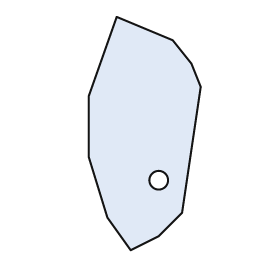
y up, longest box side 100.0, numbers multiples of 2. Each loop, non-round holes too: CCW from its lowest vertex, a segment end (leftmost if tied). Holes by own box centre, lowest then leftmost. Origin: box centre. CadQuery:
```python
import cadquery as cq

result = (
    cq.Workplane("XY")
    .moveTo(-6.0, -50.0)
    .lineTo(6.0, -44.0)
    .lineTo(16.0, -34.0)
    .lineTo(24.0, 20.0)
    .lineTo(20.0, 30.0)
    .lineTo(12.0, 40.0)
    .lineTo(-12.0, 50.0)
    .lineTo(-24.0, 16.0)
    .lineTo(-24.0, -10.0)
    .lineTo(-16.0, -36.0)
    .close()
    .moveTo(6.0, -20.0)
    .circle(4.0)
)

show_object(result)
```